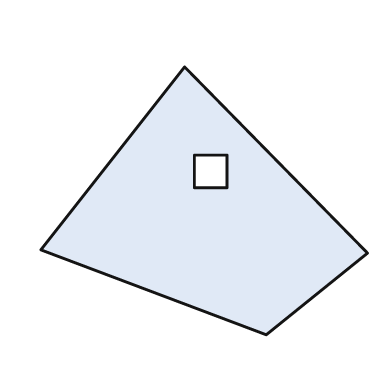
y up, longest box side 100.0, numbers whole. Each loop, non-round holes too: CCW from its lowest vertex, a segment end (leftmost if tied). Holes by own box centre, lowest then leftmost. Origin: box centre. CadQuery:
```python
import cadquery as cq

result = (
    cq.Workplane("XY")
    .moveTo(19.0, -41.0)
    .lineTo(50.0, -16.0)
    .lineTo(-6.0, 41.0)
    .lineTo(-50.0, -15.0)
    .close()
    .moveTo(-3.0, 4.0)
    .lineTo(7.0, 4.0)
    .lineTo(7.0, 14.0)
    .lineTo(-3.0, 14.0)
    .close()
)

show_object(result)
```